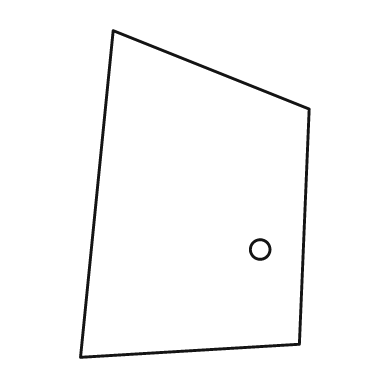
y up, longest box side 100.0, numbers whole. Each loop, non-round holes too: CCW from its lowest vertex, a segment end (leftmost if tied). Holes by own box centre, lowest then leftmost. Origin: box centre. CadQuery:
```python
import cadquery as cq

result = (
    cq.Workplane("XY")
    .moveTo(-35.0, -50.0)
    .lineTo(32.0, -46.0)
    .lineTo(35.0, 26.0)
    .lineTo(-25.0, 50.0)
    .close()
    .moveTo(20.0, -17.0)
    .circle(3.0)
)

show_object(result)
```